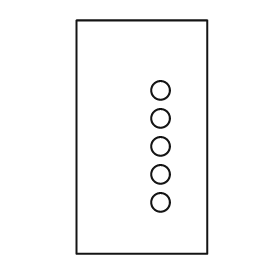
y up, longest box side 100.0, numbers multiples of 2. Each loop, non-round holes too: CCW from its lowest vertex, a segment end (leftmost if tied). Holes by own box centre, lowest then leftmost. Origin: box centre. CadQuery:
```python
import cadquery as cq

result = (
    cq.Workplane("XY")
    .moveTo(-28.0, -50.0)
    .lineTo(28.0, -50.0)
    .lineTo(28.0, 50.0)
    .lineTo(-28.0, 50.0)
    .close()
    .moveTo(8.0, -28.0)
    .circle(4.0)
    .moveTo(8.0, -16.0)
    .circle(4.0)
    .moveTo(8.0, -4.0)
    .circle(4.0)
    .moveTo(8.0, 8.0)
    .circle(4.0)
    .moveTo(8.0, 20.0)
    .circle(4.0)
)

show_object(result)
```